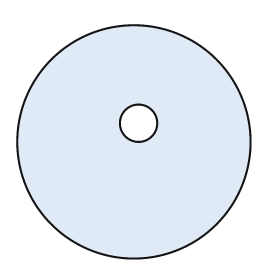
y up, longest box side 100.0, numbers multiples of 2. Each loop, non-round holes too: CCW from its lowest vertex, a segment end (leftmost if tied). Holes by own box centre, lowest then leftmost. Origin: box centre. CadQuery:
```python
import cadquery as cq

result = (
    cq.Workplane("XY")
    .moveTo(0.0, 0.0)
    .circle(50.0)
    .moveTo(2.0, 8.0)
    .circle(8.0)
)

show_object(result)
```